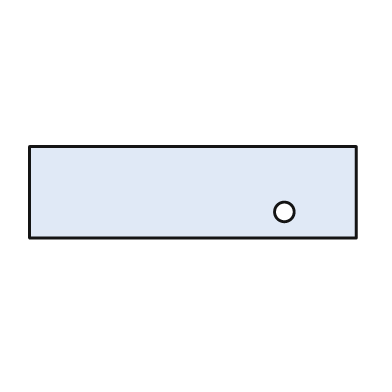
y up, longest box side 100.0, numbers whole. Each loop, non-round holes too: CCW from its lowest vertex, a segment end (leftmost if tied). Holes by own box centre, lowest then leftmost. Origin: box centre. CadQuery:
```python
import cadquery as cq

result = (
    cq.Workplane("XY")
    .moveTo(-50.0, -14.0)
    .lineTo(50.0, -14.0)
    .lineTo(50.0, 14.0)
    .lineTo(-50.0, 14.0)
    .close()
    .moveTo(28.0, -6.0)
    .circle(3.0)
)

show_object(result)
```